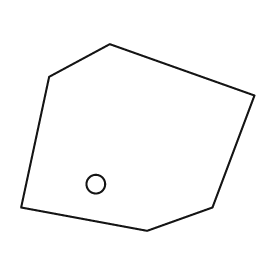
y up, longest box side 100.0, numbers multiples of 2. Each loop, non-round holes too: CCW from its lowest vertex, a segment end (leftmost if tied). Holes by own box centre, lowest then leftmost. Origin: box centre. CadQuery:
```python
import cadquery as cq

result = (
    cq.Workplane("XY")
    .moveTo(4.0, -40.0)
    .lineTo(32.0, -30.0)
    .lineTo(50.0, 18.0)
    .lineTo(-12.0, 40.0)
    .lineTo(-38.0, 26.0)
    .lineTo(-50.0, -30.0)
    .close()
    .moveTo(-18.0, -20.0)
    .circle(4.0)
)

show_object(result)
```